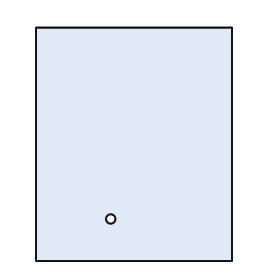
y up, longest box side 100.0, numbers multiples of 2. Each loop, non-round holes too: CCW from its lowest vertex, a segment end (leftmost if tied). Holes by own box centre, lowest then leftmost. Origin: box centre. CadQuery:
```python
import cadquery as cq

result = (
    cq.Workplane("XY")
    .moveTo(-42.0, -50.0)
    .lineTo(42.0, -50.0)
    .lineTo(42.0, 50.0)
    .lineTo(-42.0, 50.0)
    .close()
    .moveTo(-10.0, -32.0)
    .circle(2.0)
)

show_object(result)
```